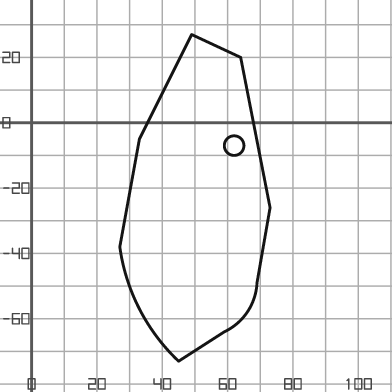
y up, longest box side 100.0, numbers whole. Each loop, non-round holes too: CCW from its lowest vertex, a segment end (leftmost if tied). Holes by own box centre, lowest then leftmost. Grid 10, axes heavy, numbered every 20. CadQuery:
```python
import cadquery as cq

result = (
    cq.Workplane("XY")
    .moveTo(45.0, -73.0)
    .lineTo(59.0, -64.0)
    .threePointArc((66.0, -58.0), (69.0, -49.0))
    .lineTo(73.0, -26.0)
    .lineTo(64.0, 20.0)
    .lineTo(49.0, 27.0)
    .lineTo(33.0, -5.0)
    .lineTo(27.0, -38.0)
    .threePointArc((33.0, -57.0), (45.0, -73.0))
    .close()
    .moveTo(62.0, -7.0)
    .circle(3.0)
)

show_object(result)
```